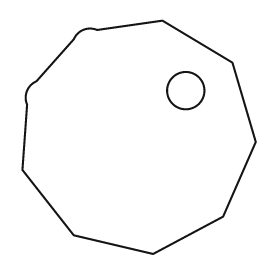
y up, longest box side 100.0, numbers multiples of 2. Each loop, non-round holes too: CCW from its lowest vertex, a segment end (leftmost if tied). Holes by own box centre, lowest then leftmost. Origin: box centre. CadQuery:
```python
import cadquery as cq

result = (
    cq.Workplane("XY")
    .moveTo(6.0, -50.0)
    .lineTo(36.0, -34.0)
    .lineTo(50.0, -2.0)
    .lineTo(40.0, 32.0)
    .lineTo(10.0, 50.0)
    .lineTo(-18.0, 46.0)
    .threePointArc((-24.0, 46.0), (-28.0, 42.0))
    .lineTo(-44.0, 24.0)
    .threePointArc((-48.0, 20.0), (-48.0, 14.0))
    .lineTo(-50.0, -14.0)
    .lineTo(-28.0, -42.0)
    .close()
    .moveTo(20.0, 20.0)
    .circle(8.0)
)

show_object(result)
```